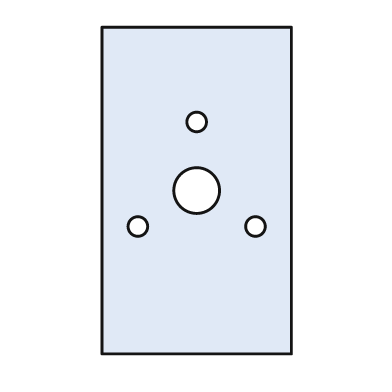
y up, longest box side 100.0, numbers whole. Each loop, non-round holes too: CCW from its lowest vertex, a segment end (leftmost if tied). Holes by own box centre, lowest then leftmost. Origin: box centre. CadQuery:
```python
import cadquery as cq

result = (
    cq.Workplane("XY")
    .moveTo(-29.0, -50.0)
    .lineTo(29.0, -50.0)
    .lineTo(29.0, 50.0)
    .lineTo(-29.0, 50.0)
    .close()
    .moveTo(-18.0, -11.0)
    .circle(3.0)
    .moveTo(18.0, -11.0)
    .circle(3.0)
    .moveTo(0.0, 0.0)
    .circle(7.0)
    .moveTo(0.0, 21.0)
    .circle(3.0)
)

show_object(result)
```